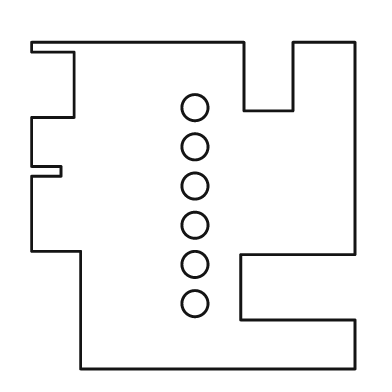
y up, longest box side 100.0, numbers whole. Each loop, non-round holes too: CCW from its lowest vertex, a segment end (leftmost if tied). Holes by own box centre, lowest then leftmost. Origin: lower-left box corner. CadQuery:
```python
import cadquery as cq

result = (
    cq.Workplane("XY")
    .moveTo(15.0, 0.0)
    .lineTo(99.0, 0.0)
    .lineTo(99.0, 15.0)
    .lineTo(64.0, 15.0)
    .lineTo(64.0, 35.0)
    .lineTo(99.0, 35.0)
    .lineTo(99.0, 100.0)
    .lineTo(80.0, 100.0)
    .lineTo(80.0, 79.0)
    .lineTo(65.0, 79.0)
    .lineTo(65.0, 100.0)
    .lineTo(0.0, 100.0)
    .lineTo(0.0, 97.0)
    .lineTo(13.0, 97.0)
    .lineTo(13.0, 77.0)
    .lineTo(0.0, 77.0)
    .lineTo(0.0, 62.0)
    .lineTo(9.0, 62.0)
    .lineTo(9.0, 59.0)
    .lineTo(0.0, 59.0)
    .lineTo(0.0, 36.0)
    .lineTo(15.0, 36.0)
    .close()
    .moveTo(50.0, 20.0)
    .circle(4.0)
    .moveTo(50.0, 32.0)
    .circle(4.0)
    .moveTo(50.0, 44.0)
    .circle(4.0)
    .moveTo(50.0, 56.0)
    .circle(4.0)
    .moveTo(50.0, 68.0)
    .circle(4.0)
    .moveTo(50.0, 80.0)
    .circle(4.0)
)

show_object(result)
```